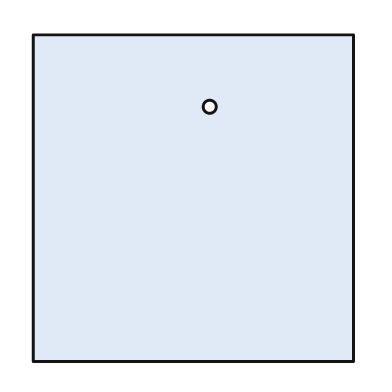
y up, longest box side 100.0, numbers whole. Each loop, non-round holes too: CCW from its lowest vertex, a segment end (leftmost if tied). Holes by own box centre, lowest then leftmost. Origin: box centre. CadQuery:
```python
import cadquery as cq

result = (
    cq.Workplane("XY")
    .moveTo(-49.0, -50.0)
    .lineTo(49.0, -50.0)
    .lineTo(49.0, 50.0)
    .lineTo(-49.0, 50.0)
    .close()
    .moveTo(5.0, 28.0)
    .circle(2.0)
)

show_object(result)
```